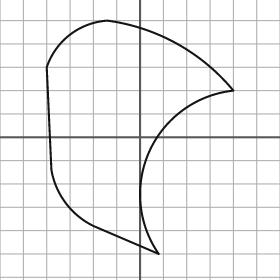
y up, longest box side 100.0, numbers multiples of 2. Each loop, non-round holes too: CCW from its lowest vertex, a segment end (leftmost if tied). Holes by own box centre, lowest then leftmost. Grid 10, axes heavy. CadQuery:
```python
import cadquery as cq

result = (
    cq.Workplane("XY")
    .moveTo(8.0, -50.0)
    .threePointArc((4.0, -6.0), (40.0, 20.0))
    .threePointArc((16.0, 40.0), (-14.0, 50.0))
    .threePointArc((-30.0, 44.0), (-40.0, 30.0))
    .lineTo(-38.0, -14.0)
    .threePointArc((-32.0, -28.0), (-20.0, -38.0))
    .close()
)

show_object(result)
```